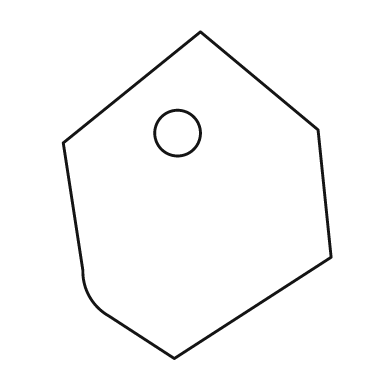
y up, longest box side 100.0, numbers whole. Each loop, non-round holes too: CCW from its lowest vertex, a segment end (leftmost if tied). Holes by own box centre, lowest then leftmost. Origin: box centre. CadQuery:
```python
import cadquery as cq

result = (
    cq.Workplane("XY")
    .moveTo(-7.0, -50.0)
    .lineTo(41.0, -19.0)
    .lineTo(37.0, 20.0)
    .lineTo(1.0, 50.0)
    .lineTo(-41.0, 16.0)
    .lineTo(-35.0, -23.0)
    .threePointArc((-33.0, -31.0), (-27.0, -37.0))
    .close()
    .moveTo(-6.0, 19.0)
    .circle(7.0)
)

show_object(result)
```